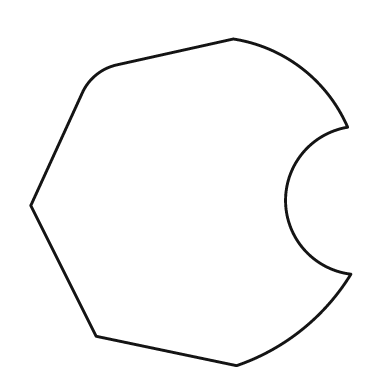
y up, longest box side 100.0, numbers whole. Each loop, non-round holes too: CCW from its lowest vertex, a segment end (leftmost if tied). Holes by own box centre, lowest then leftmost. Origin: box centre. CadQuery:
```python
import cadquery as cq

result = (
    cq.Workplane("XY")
    .moveTo(14.0, -50.0)
    .threePointArc((34.0, -39.0), (49.0, -22.0))
    .threePointArc((29.0, 0.0), (48.0, 23.0))
    .threePointArc((34.0, 41.0), (13.0, 50.0))
    .lineTo(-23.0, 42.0)
    .threePointArc((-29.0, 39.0), (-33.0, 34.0))
    .lineTo(-49.0, -1.0)
    .lineTo(-29.0, -41.0)
    .close()
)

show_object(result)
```